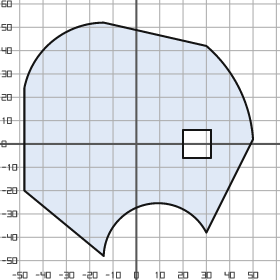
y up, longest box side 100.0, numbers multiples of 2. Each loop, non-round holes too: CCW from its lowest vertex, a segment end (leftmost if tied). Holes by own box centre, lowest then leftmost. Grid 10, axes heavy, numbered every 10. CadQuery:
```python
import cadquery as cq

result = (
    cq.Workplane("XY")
    .moveTo(-14.0, -48.0)
    .threePointArc((4.0, -26.0), (30.0, -38.0))
    .lineTo(50.0, 2.0)
    .threePointArc((44.0, 24.0), (30.0, 42.0))
    .lineTo(-14.0, 52.0)
    .threePointArc((-36.0, 44.0), (-48.0, 24.0))
    .lineTo(-48.0, -20.0)
    .close()
    .moveTo(20.0, -6.0)
    .lineTo(32.0, -6.0)
    .lineTo(32.0, 6.0)
    .lineTo(20.0, 6.0)
    .close()
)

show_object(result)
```